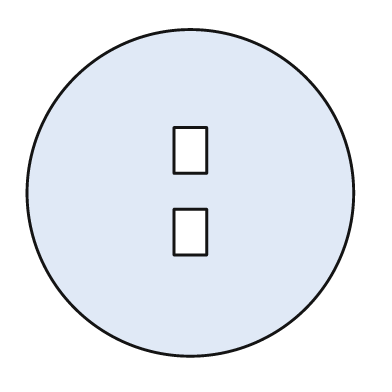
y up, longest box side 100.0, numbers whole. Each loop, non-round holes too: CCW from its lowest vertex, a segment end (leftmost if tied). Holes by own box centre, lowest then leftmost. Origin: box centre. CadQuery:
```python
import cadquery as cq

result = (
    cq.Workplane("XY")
    .moveTo(0.0, 0.0)
    .circle(50.0)
    .moveTo(-5.0, -19.0)
    .lineTo(5.0, -19.0)
    .lineTo(5.0, -5.0)
    .lineTo(-5.0, -5.0)
    .close()
    .moveTo(-5.0, 6.0)
    .lineTo(5.0, 6.0)
    .lineTo(5.0, 20.0)
    .lineTo(-5.0, 20.0)
    .close()
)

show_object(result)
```